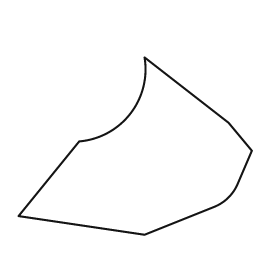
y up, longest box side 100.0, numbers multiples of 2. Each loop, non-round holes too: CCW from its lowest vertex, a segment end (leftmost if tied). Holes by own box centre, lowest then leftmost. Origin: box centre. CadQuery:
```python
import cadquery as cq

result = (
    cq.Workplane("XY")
    .moveTo(4.0, -38.0)
    .lineTo(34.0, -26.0)
    .threePointArc((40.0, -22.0), (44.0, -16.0))
    .lineTo(50.0, -2.0)
    .lineTo(40.0, 10.0)
    .lineTo(4.0, 38.0)
    .threePointArc((-2.0, 14.0), (-24.0, 2.0))
    .lineTo(-50.0, -30.0)
    .close()
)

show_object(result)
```